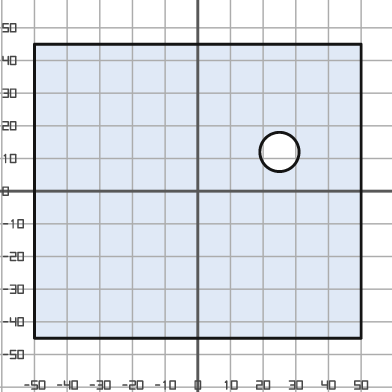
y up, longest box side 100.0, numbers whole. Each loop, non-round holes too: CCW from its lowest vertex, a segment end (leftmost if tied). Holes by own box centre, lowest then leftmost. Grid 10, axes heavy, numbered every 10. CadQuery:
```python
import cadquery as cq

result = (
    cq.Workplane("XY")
    .moveTo(-50.0, -45.0)
    .lineTo(50.0, -45.0)
    .lineTo(50.0, 45.0)
    .lineTo(-50.0, 45.0)
    .close()
    .moveTo(25.0, 12.0)
    .circle(6.0)
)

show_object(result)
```